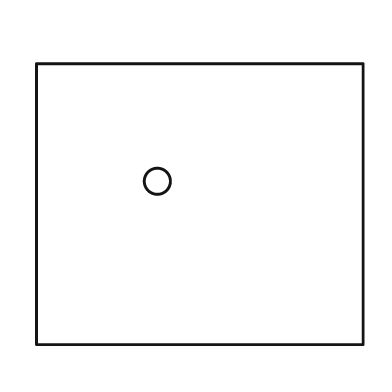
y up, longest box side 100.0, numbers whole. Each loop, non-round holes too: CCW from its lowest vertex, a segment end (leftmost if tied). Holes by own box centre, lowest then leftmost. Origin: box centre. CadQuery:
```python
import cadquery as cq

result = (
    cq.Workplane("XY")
    .moveTo(-50.0, -43.0)
    .lineTo(50.0, -43.0)
    .lineTo(50.0, 43.0)
    .lineTo(-50.0, 43.0)
    .close()
    .moveTo(-13.0, 7.0)
    .circle(4.0)
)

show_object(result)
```